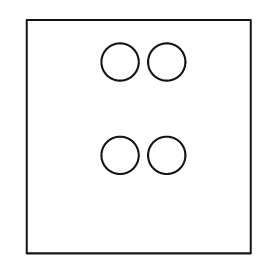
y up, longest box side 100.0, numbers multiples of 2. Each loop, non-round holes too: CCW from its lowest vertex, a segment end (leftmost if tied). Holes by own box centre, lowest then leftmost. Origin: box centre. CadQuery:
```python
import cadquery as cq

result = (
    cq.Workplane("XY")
    .moveTo(-48.0, -50.0)
    .lineTo(48.0, -50.0)
    .lineTo(48.0, 50.0)
    .lineTo(-48.0, 50.0)
    .close()
    .moveTo(-8.0, -8.0)
    .circle(8.0)
    .moveTo(12.0, -8.0)
    .circle(8.0)
    .moveTo(-8.0, 32.0)
    .circle(8.0)
    .moveTo(12.0, 32.0)
    .circle(8.0)
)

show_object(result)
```